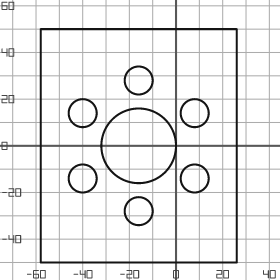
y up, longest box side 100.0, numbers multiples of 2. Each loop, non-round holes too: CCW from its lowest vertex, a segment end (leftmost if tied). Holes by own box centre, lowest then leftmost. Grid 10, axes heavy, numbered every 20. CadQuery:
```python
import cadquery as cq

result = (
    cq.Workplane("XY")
    .moveTo(-58.0, -50.0)
    .lineTo(26.0, -50.0)
    .lineTo(26.0, 50.0)
    .lineTo(-58.0, 50.0)
    .close()
    .moveTo(-16.0, -28.0)
    .circle(6.0)
    .moveTo(-40.0, -14.0)
    .circle(6.0)
    .moveTo(8.0, -14.0)
    .circle(6.0)
    .moveTo(-16.0, 0.0)
    .circle(16.0)
    .moveTo(-40.0, 14.0)
    .circle(6.0)
    .moveTo(8.0, 14.0)
    .circle(6.0)
    .moveTo(-16.0, 28.0)
    .circle(6.0)
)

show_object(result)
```